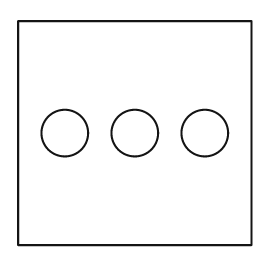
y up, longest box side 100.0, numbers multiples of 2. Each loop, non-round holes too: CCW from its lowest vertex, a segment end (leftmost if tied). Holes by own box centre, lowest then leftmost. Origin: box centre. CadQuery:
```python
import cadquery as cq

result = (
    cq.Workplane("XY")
    .moveTo(-50.0, -48.0)
    .lineTo(50.0, -48.0)
    .lineTo(50.0, 48.0)
    .lineTo(-50.0, 48.0)
    .close()
    .moveTo(-30.0, 0.0)
    .circle(10.0)
    .moveTo(0.0, 0.0)
    .circle(10.0)
    .moveTo(30.0, 0.0)
    .circle(10.0)
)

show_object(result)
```